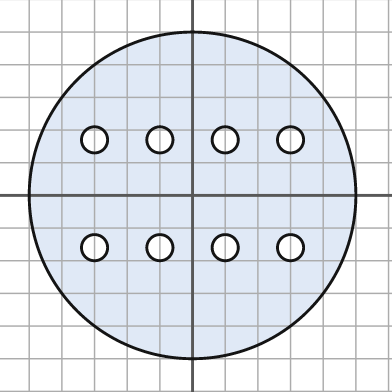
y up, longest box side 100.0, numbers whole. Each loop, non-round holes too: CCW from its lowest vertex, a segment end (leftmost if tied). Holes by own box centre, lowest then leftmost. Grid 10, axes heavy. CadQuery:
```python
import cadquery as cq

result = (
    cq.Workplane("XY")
    .moveTo(0.0, 0.0)
    .circle(50.0)
    .moveTo(-30.0, -16.0)
    .circle(4.0)
    .moveTo(-10.0, -16.0)
    .circle(4.0)
    .moveTo(10.0, -16.0)
    .circle(4.0)
    .moveTo(30.0, -16.0)
    .circle(4.0)
    .moveTo(-30.0, 17.0)
    .circle(4.0)
    .moveTo(-10.0, 17.0)
    .circle(4.0)
    .moveTo(10.0, 17.0)
    .circle(4.0)
    .moveTo(30.0, 17.0)
    .circle(4.0)
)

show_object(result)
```